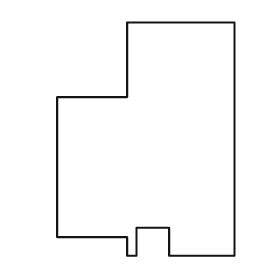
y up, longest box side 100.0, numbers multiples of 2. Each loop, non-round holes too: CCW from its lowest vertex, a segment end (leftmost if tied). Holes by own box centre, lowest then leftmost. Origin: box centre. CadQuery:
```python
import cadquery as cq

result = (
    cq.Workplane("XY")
    .moveTo(-8.0, -50.0)
    .lineTo(-4.0, -50.0)
    .lineTo(-4.0, -38.0)
    .lineTo(10.0, -38.0)
    .lineTo(10.0, -50.0)
    .lineTo(38.0, -50.0)
    .lineTo(38.0, 50.0)
    .lineTo(-8.0, 50.0)
    .lineTo(-8.0, 18.0)
    .lineTo(-38.0, 18.0)
    .lineTo(-38.0, -42.0)
    .lineTo(-8.0, -42.0)
    .close()
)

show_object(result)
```